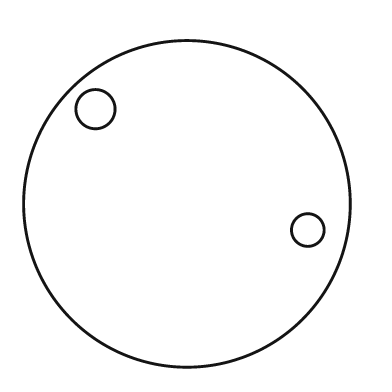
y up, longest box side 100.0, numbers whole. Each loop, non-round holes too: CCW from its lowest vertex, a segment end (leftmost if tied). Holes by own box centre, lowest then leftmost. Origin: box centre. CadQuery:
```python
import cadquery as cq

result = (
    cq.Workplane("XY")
    .moveTo(0.0, 0.0)
    .circle(50.0)
    .moveTo(37.0, -8.0)
    .circle(5.0)
    .moveTo(-28.0, 29.0)
    .circle(6.0)
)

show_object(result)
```